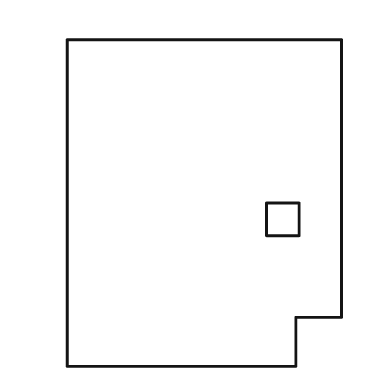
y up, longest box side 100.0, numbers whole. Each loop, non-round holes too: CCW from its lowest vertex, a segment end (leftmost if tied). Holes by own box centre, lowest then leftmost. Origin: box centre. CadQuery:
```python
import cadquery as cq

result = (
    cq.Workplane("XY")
    .moveTo(-42.0, -50.0)
    .lineTo(28.0, -50.0)
    .lineTo(28.0, -35.0)
    .lineTo(42.0, -35.0)
    .lineTo(42.0, 50.0)
    .lineTo(-42.0, 50.0)
    .close()
    .moveTo(19.0, -10.0)
    .lineTo(29.0, -10.0)
    .lineTo(29.0, 0.0)
    .lineTo(19.0, 0.0)
    .close()
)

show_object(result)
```